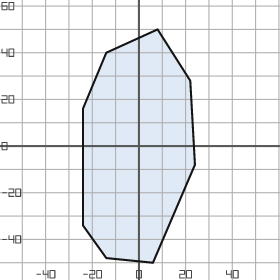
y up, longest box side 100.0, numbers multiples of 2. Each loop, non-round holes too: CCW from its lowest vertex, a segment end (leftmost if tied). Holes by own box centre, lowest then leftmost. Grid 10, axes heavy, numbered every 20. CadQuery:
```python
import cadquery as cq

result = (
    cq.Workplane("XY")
    .moveTo(6.0, -50.0)
    .lineTo(24.0, -8.0)
    .lineTo(22.0, 28.0)
    .lineTo(8.0, 50.0)
    .lineTo(-14.0, 40.0)
    .lineTo(-24.0, 16.0)
    .lineTo(-24.0, -34.0)
    .lineTo(-14.0, -48.0)
    .close()
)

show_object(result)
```